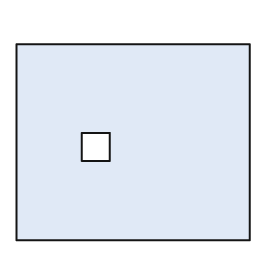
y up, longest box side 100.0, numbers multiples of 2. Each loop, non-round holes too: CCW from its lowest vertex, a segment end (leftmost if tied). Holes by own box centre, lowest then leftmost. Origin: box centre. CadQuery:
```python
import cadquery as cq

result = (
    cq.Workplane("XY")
    .moveTo(-50.0, -42.0)
    .lineTo(50.0, -42.0)
    .lineTo(50.0, 42.0)
    .lineTo(-50.0, 42.0)
    .close()
    .moveTo(-22.0, -8.0)
    .lineTo(-10.0, -8.0)
    .lineTo(-10.0, 4.0)
    .lineTo(-22.0, 4.0)
    .close()
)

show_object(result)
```